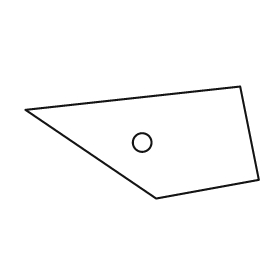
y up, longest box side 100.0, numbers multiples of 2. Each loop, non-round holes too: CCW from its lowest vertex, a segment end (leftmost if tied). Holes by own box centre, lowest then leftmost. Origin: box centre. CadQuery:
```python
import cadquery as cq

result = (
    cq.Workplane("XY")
    .moveTo(6.0, -24.0)
    .lineTo(50.0, -16.0)
    .lineTo(42.0, 24.0)
    .lineTo(-50.0, 14.0)
    .close()
    .moveTo(0.0, 0.0)
    .circle(4.0)
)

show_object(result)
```